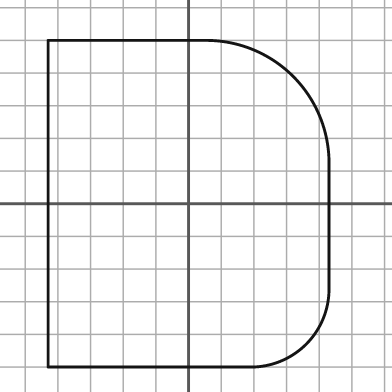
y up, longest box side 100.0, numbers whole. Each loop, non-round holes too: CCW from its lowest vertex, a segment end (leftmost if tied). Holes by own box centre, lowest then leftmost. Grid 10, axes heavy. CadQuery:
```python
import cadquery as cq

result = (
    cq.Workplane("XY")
    .moveTo(-43.0, -50.0)
    .lineTo(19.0, -50.0)
    .threePointArc((36.0, -43.0), (43.0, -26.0))
    .lineTo(43.0, 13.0)
    .threePointArc((32.0, 39.0), (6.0, 50.0))
    .lineTo(-43.0, 50.0)
    .close()
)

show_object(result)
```